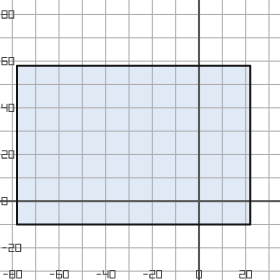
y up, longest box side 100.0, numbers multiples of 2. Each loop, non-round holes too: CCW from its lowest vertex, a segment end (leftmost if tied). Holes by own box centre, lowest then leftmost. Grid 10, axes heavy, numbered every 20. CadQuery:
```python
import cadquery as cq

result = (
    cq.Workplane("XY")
    .moveTo(-78.0, -10.0)
    .lineTo(22.0, -10.0)
    .lineTo(22.0, 58.0)
    .lineTo(-78.0, 58.0)
    .close()
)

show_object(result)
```